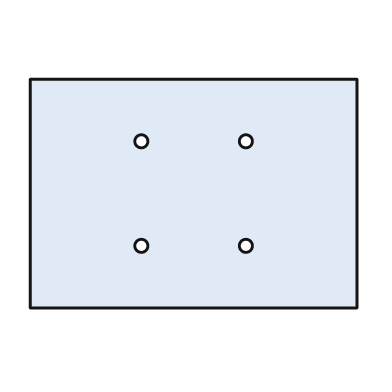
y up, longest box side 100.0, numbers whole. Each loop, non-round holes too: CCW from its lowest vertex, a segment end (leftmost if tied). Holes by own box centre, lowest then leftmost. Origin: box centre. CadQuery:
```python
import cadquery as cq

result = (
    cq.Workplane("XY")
    .moveTo(-50.0, -35.0)
    .lineTo(50.0, -35.0)
    .lineTo(50.0, 35.0)
    .lineTo(-50.0, 35.0)
    .close()
    .moveTo(-16.0, -16.0)
    .circle(2.0)
    .moveTo(16.0, -16.0)
    .circle(2.0)
    .moveTo(-16.0, 16.0)
    .circle(2.0)
    .moveTo(16.0, 16.0)
    .circle(2.0)
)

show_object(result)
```